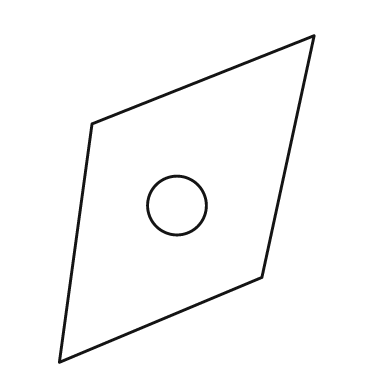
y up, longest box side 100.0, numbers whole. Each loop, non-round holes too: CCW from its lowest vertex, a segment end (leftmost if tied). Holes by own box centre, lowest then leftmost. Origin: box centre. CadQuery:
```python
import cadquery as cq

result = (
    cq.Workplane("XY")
    .moveTo(-39.0, -50.0)
    .lineTo(23.0, -24.0)
    .lineTo(39.0, 50.0)
    .lineTo(-29.0, 23.0)
    .close()
    .moveTo(-3.0, -2.0)
    .circle(9.0)
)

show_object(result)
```